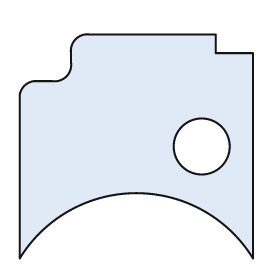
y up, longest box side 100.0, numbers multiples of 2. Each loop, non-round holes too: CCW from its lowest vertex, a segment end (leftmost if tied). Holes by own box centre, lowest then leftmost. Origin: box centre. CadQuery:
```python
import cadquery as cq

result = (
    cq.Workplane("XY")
    .moveTo(-50.0, -48.0)
    .threePointArc((0.0, -20.0), (50.0, -48.0))
    .lineTo(50.0, 40.0)
    .lineTo(34.0, 40.0)
    .lineTo(34.0, 48.0)
    .lineTo(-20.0, 48.0)
    .threePointArc((-26.0, 46.0), (-28.0, 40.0))
    .lineTo(-28.0, 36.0)
    .threePointArc((-30.0, 30.0), (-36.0, 28.0))
    .lineTo(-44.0, 28.0)
    .threePointArc((-48.0, 26.0), (-50.0, 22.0))
    .close()
    .moveTo(28.0, 0.0)
    .circle(12.0)
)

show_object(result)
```